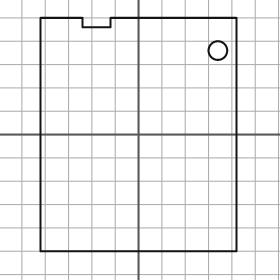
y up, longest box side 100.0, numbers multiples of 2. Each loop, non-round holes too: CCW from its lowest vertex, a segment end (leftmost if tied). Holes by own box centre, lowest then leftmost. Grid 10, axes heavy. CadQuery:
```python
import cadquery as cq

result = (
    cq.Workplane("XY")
    .moveTo(-42.0, -50.0)
    .lineTo(42.0, -50.0)
    .lineTo(42.0, 50.0)
    .lineTo(-12.0, 50.0)
    .lineTo(-12.0, 46.0)
    .lineTo(-24.0, 46.0)
    .lineTo(-24.0, 50.0)
    .lineTo(-42.0, 50.0)
    .close()
    .moveTo(34.0, 36.0)
    .circle(4.0)
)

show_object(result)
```